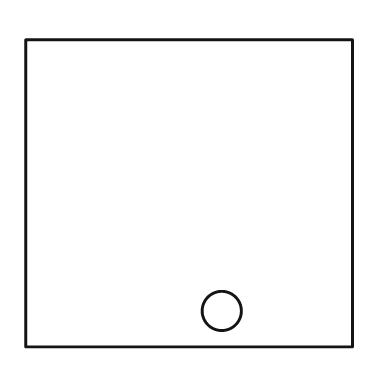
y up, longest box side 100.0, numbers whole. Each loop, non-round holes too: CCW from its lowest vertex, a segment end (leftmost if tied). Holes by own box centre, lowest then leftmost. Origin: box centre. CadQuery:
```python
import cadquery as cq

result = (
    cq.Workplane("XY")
    .moveTo(-50.0, -47.0)
    .lineTo(50.0, -47.0)
    .lineTo(50.0, 47.0)
    .lineTo(-50.0, 47.0)
    .close()
    .moveTo(10.0, -36.0)
    .circle(6.0)
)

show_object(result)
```